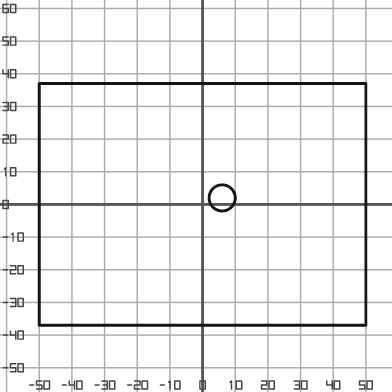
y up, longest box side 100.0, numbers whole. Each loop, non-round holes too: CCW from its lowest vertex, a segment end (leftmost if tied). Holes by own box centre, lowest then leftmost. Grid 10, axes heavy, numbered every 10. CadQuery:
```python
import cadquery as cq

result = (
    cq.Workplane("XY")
    .moveTo(-50.0, -37.0)
    .lineTo(50.0, -37.0)
    .lineTo(50.0, 37.0)
    .lineTo(-50.0, 37.0)
    .close()
    .moveTo(6.0, 2.0)
    .circle(4.0)
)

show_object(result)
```